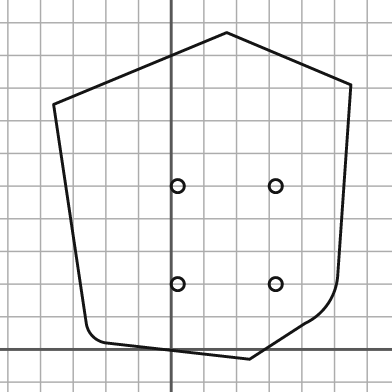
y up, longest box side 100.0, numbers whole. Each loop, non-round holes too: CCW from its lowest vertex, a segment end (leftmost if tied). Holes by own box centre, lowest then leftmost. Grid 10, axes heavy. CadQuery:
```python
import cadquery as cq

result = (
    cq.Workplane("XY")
    .moveTo(24.0, -3.0)
    .lineTo(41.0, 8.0)
    .threePointArc((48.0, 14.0), (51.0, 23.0))
    .lineTo(55.0, 81.0)
    .lineTo(17.0, 97.0)
    .lineTo(-36.0, 75.0)
    .lineTo(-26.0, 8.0)
    .threePointArc((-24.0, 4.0), (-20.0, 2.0))
    .close()
    .moveTo(2.0, 20.0)
    .circle(2.0)
    .moveTo(32.0, 20.0)
    .circle(2.0)
    .moveTo(2.0, 50.0)
    .circle(2.0)
    .moveTo(32.0, 50.0)
    .circle(2.0)
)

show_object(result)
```